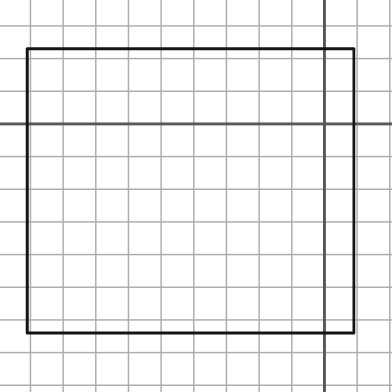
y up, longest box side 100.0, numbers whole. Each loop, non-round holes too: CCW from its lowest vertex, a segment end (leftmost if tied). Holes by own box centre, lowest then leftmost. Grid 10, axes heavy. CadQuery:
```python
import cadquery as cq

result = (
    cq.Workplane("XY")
    .moveTo(-91.0, -64.0)
    .lineTo(9.0, -64.0)
    .lineTo(9.0, 23.0)
    .lineTo(-91.0, 23.0)
    .close()
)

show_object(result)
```